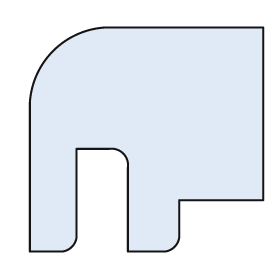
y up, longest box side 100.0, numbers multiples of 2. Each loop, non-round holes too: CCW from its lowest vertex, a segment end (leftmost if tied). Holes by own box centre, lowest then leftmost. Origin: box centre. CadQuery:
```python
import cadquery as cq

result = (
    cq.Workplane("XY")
    .moveTo(-50.0, -48.0)
    .lineTo(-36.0, -48.0)
    .threePointArc((-32.0, -46.0), (-30.0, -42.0))
    .lineTo(-30.0, -4.0)
    .lineTo(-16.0, -4.0)
    .threePointArc((-10.0, -6.0), (-8.0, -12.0))
    .lineTo(-8.0, -48.0)
    .lineTo(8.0, -48.0)
    .threePointArc((12.0, -46.0), (14.0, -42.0))
    .lineTo(14.0, -26.0)
    .lineTo(50.0, -26.0)
    .lineTo(50.0, 48.0)
    .lineTo(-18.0, 48.0)
    .threePointArc((-40.0, 38.0), (-50.0, 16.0))
    .close()
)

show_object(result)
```